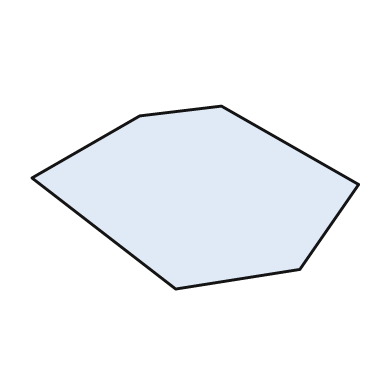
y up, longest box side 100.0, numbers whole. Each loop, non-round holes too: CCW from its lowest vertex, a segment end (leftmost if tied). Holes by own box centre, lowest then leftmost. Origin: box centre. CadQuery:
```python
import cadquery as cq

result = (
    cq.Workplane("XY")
    .moveTo(-6.0, -28.0)
    .lineTo(32.0, -22.0)
    .lineTo(50.0, 4.0)
    .lineTo(8.0, 28.0)
    .lineTo(-17.0, 25.0)
    .lineTo(-50.0, 6.0)
    .close()
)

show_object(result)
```